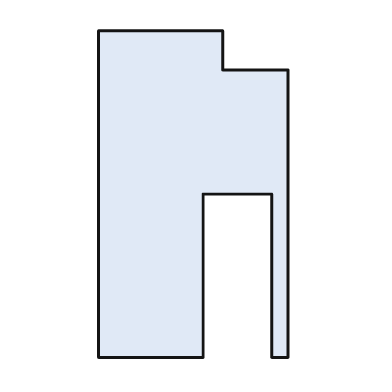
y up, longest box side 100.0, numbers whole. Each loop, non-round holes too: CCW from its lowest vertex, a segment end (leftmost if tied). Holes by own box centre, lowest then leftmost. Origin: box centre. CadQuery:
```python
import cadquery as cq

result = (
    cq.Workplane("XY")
    .moveTo(-29.0, -50.0)
    .lineTo(3.0, -50.0)
    .lineTo(3.0, 0.0)
    .lineTo(24.0, 0.0)
    .lineTo(24.0, -50.0)
    .lineTo(29.0, -50.0)
    .lineTo(29.0, 38.0)
    .lineTo(9.0, 38.0)
    .lineTo(9.0, 50.0)
    .lineTo(-29.0, 50.0)
    .close()
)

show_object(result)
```